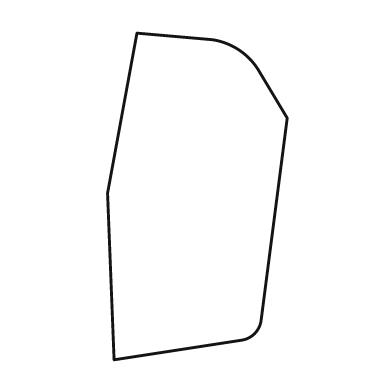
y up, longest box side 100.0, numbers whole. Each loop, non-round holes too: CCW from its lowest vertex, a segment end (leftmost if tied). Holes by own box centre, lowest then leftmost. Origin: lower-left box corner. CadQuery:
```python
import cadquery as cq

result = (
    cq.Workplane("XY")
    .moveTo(2.0, 0.0)
    .lineTo(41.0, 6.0)
    .threePointArc((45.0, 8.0), (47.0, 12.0))
    .lineTo(55.0, 74.0)
    .lineTo(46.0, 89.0)
    .threePointArc((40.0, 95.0), (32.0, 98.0))
    .lineTo(9.0, 100.0)
    .lineTo(0.0, 51.0)
    .close()
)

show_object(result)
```